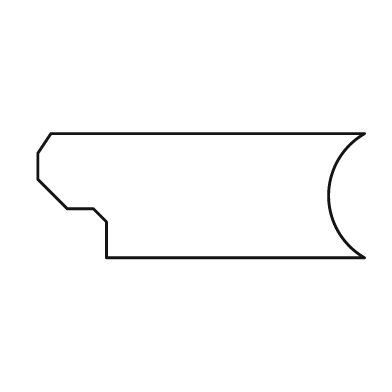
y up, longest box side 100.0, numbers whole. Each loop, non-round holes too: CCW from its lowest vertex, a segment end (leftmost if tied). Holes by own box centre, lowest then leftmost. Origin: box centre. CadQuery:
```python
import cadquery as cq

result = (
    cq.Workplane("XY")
    .moveTo(-29.0, -19.0)
    .lineTo(50.0, -19.0)
    .threePointArc((39.0, 0.0), (50.0, 19.0))
    .lineTo(-46.0, 19.0)
    .lineTo(-50.0, 13.0)
    .lineTo(-50.0, 5.0)
    .lineTo(-41.0, -4.0)
    .lineTo(-33.0, -4.0)
    .lineTo(-29.0, -8.0)
    .close()
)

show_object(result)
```